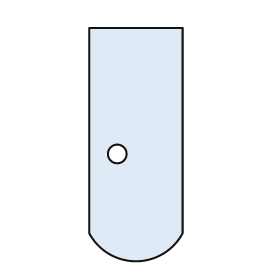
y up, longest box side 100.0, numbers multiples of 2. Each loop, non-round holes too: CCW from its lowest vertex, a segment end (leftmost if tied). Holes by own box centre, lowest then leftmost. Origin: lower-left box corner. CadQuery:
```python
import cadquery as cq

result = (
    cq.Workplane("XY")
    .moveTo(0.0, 12.0)
    .threePointArc((20.0, 0.0), (40.0, 12.0))
    .lineTo(40.0, 100.0)
    .lineTo(0.0, 100.0)
    .close()
    .moveTo(12.0, 46.0)
    .circle(4.0)
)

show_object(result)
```